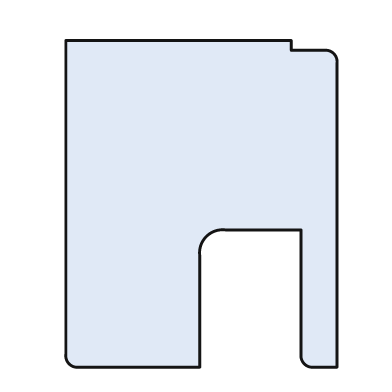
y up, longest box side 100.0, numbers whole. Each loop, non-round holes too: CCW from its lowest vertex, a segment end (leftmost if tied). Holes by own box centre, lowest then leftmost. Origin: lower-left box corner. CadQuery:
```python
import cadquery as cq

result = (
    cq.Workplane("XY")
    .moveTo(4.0, 0.0)
    .lineTo(41.0, 0.0)
    .lineTo(41.0, 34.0)
    .threePointArc((43.0, 40.0), (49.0, 42.0))
    .lineTo(72.0, 42.0)
    .lineTo(72.0, 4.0)
    .threePointArc((73.0, 1.0), (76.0, 0.0))
    .lineTo(83.0, 0.0)
    .lineTo(83.0, 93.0)
    .threePointArc((82.0, 96.0), (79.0, 97.0))
    .lineTo(69.0, 97.0)
    .lineTo(69.0, 100.0)
    .lineTo(0.0, 100.0)
    .lineTo(0.0, 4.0)
    .threePointArc((1.0, 1.0), (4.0, 0.0))
    .close()
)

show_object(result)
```